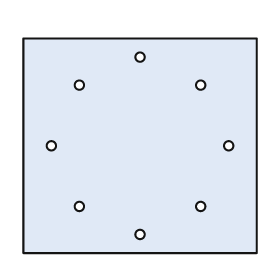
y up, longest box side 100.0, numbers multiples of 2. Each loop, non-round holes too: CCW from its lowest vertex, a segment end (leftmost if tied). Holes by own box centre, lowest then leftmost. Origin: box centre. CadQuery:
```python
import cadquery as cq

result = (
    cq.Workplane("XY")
    .moveTo(-50.0, -46.0)
    .lineTo(50.0, -46.0)
    .lineTo(50.0, 46.0)
    .lineTo(-50.0, 46.0)
    .close()
    .moveTo(0.0, -38.0)
    .circle(2.0)
    .moveTo(-26.0, -26.0)
    .circle(2.0)
    .moveTo(26.0, -26.0)
    .circle(2.0)
    .moveTo(-38.0, 0.0)
    .circle(2.0)
    .moveTo(38.0, 0.0)
    .circle(2.0)
    .moveTo(-26.0, 26.0)
    .circle(2.0)
    .moveTo(26.0, 26.0)
    .circle(2.0)
    .moveTo(0.0, 38.0)
    .circle(2.0)
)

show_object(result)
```